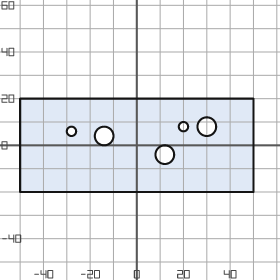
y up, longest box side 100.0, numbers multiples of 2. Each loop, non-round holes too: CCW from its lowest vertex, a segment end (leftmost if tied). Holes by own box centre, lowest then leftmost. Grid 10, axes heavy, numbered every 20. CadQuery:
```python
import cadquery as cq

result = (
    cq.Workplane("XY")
    .moveTo(-50.0, -20.0)
    .lineTo(50.0, -20.0)
    .lineTo(50.0, 20.0)
    .lineTo(-50.0, 20.0)
    .close()
    .moveTo(12.0, -4.0)
    .circle(4.0)
    .moveTo(-14.0, 4.0)
    .circle(4.0)
    .moveTo(-28.0, 6.0)
    .circle(2.0)
    .moveTo(20.0, 8.0)
    .circle(2.0)
    .moveTo(30.0, 8.0)
    .circle(4.0)
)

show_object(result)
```